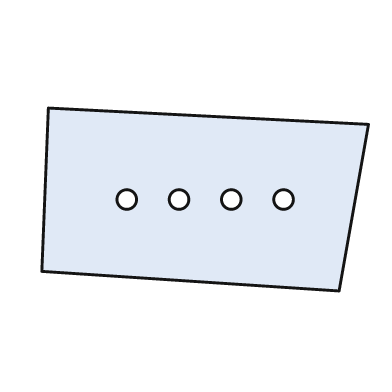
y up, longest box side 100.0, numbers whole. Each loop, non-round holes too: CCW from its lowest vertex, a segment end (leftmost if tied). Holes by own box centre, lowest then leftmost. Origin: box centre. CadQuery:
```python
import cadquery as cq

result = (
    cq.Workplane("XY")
    .moveTo(41.0, -28.0)
    .lineTo(50.0, 23.0)
    .lineTo(-48.0, 28.0)
    .lineTo(-50.0, -22.0)
    .close()
    .moveTo(-24.0, 0.0)
    .circle(3.0)
    .moveTo(-8.0, 0.0)
    .circle(3.0)
    .moveTo(8.0, 0.0)
    .circle(3.0)
    .moveTo(24.0, 0.0)
    .circle(3.0)
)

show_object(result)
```